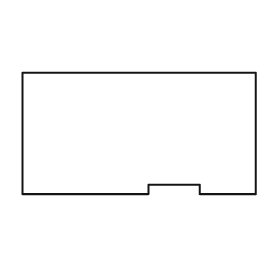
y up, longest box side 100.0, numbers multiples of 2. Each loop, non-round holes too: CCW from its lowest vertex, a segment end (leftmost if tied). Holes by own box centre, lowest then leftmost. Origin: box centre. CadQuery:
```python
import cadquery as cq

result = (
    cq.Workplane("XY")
    .moveTo(-50.0, -26.0)
    .lineTo(4.0, -26.0)
    .lineTo(4.0, -22.0)
    .lineTo(26.0, -22.0)
    .lineTo(26.0, -26.0)
    .lineTo(50.0, -26.0)
    .lineTo(50.0, 26.0)
    .lineTo(-50.0, 26.0)
    .close()
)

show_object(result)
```